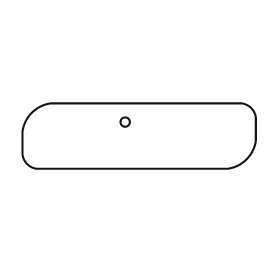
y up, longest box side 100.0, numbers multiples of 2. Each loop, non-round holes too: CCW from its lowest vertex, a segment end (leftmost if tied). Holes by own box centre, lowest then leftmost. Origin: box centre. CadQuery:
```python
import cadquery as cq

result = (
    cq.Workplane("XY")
    .moveTo(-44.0, -14.0)
    .lineTo(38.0, -14.0)
    .threePointArc((46.0, -10.0), (50.0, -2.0))
    .lineTo(50.0, 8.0)
    .threePointArc((48.0, 12.0), (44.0, 14.0))
    .lineTo(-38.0, 14.0)
    .threePointArc((-46.0, 10.0), (-50.0, 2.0))
    .lineTo(-50.0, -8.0)
    .threePointArc((-48.0, -12.0), (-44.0, -14.0))
    .close()
    .moveTo(-6.0, 6.0)
    .circle(2.0)
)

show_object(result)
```